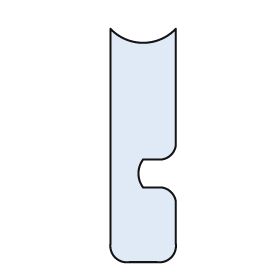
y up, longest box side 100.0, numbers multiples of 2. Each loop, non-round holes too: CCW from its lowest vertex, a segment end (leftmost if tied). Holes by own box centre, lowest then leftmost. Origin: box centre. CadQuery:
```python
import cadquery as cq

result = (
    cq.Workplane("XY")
    .moveTo(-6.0, -50.0)
    .lineTo(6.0, -50.0)
    .threePointArc((12.0, -48.0), (14.0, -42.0))
    .lineTo(14.0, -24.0)
    .threePointArc((12.0, -20.0), (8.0, -18.0))
    .lineTo(0.0, -18.0)
    .threePointArc((-2.0, -12.0), (0.0, -6.0))
    .lineTo(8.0, -6.0)
    .threePointArc((12.0, -4.0), (14.0, 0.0))
    .lineTo(14.0, 50.0)
    .threePointArc((0.0, 44.0), (-14.0, 50.0))
    .lineTo(-14.0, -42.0)
    .threePointArc((-12.0, -48.0), (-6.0, -50.0))
    .close()
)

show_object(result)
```